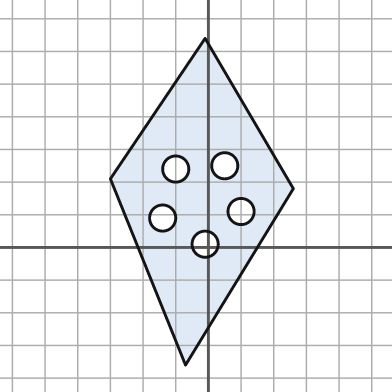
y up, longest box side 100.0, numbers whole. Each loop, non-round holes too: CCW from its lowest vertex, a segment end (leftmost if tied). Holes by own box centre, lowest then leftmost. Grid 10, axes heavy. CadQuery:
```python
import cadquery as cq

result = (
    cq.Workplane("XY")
    .moveTo(-7.0, -36.0)
    .lineTo(26.0, 18.0)
    .lineTo(-1.0, 64.0)
    .lineTo(-30.0, 21.0)
    .close()
    .moveTo(-1.0, 1.0)
    .circle(4.0)
    .moveTo(-14.0, 9.0)
    .circle(4.0)
    .moveTo(10.0, 11.0)
    .circle(4.0)
    .moveTo(-10.0, 24.0)
    .circle(4.0)
    .moveTo(5.0, 25.0)
    .circle(4.0)
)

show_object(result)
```